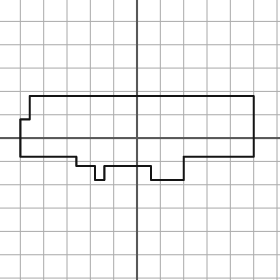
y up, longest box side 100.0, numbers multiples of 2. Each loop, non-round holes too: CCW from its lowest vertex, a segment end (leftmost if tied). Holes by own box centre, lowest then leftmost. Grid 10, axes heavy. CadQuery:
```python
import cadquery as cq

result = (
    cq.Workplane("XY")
    .moveTo(-18.0, -18.0)
    .lineTo(-14.0, -18.0)
    .lineTo(-14.0, -12.0)
    .lineTo(6.0, -12.0)
    .lineTo(6.0, -18.0)
    .lineTo(20.0, -18.0)
    .lineTo(20.0, -8.0)
    .lineTo(50.0, -8.0)
    .lineTo(50.0, 18.0)
    .lineTo(-46.0, 18.0)
    .lineTo(-46.0, 8.0)
    .lineTo(-50.0, 8.0)
    .lineTo(-50.0, -8.0)
    .lineTo(-26.0, -8.0)
    .lineTo(-26.0, -12.0)
    .lineTo(-18.0, -12.0)
    .close()
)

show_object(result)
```